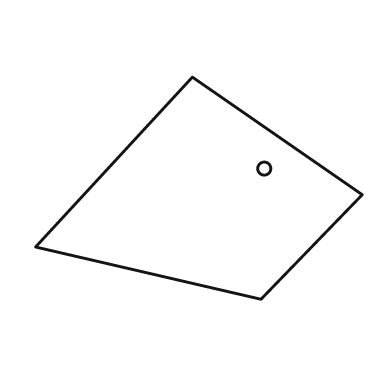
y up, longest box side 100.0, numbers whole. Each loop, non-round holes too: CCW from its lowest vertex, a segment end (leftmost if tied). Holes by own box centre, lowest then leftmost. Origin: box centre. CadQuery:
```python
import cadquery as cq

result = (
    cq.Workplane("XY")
    .moveTo(19.0, -34.0)
    .lineTo(50.0, -2.0)
    .lineTo(-2.0, 34.0)
    .lineTo(-50.0, -18.0)
    .close()
    .moveTo(20.0, 6.0)
    .circle(2.0)
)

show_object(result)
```